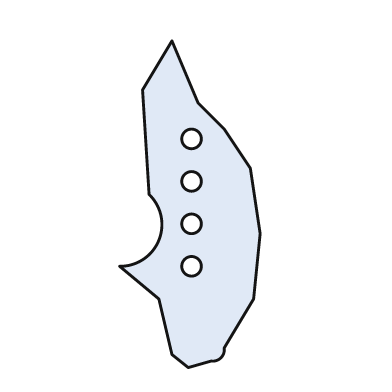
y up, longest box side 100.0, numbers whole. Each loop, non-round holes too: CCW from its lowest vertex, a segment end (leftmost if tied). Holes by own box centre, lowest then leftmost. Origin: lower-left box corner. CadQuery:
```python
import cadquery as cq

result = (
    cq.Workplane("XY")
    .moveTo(21.0, 0.0)
    .lineTo(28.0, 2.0)
    .threePointArc((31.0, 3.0), (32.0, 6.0))
    .lineTo(41.0, 21.0)
    .lineTo(43.0, 41.0)
    .lineTo(40.0, 61.0)
    .lineTo(32.0, 73.0)
    .lineTo(24.0, 81.0)
    .lineTo(16.0, 100.0)
    .lineTo(7.0, 85.0)
    .lineTo(9.0, 53.0)
    .threePointArc((12.0, 39.0), (0.0, 31.0))
    .lineTo(12.0, 21.0)
    .lineTo(16.0, 4.0)
    .close()
    .moveTo(22.0, 31.0)
    .circle(3.0)
    .moveTo(22.0, 44.0)
    .circle(3.0)
    .moveTo(22.0, 57.0)
    .circle(3.0)
    .moveTo(22.0, 70.0)
    .circle(3.0)
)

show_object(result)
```